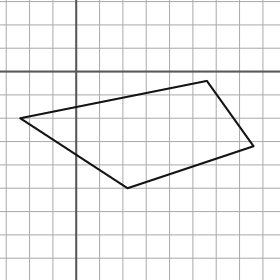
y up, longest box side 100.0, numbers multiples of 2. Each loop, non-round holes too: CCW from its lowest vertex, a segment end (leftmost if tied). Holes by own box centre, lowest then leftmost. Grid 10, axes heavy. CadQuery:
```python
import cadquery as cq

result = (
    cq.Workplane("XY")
    .moveTo(22.0, -50.0)
    .lineTo(76.0, -32.0)
    .lineTo(56.0, -4.0)
    .lineTo(-24.0, -20.0)
    .close()
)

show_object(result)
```